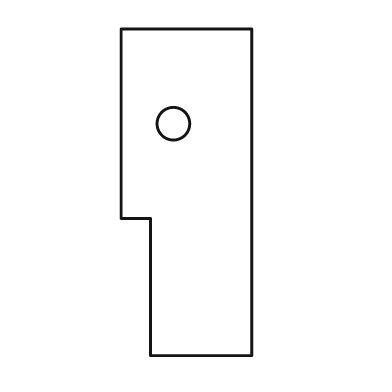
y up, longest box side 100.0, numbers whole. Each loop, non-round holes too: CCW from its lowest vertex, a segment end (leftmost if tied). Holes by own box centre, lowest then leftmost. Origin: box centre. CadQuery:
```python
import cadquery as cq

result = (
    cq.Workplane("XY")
    .moveTo(-11.0, -50.0)
    .lineTo(20.0, -50.0)
    .lineTo(20.0, 50.0)
    .lineTo(-20.0, 50.0)
    .lineTo(-20.0, -8.0)
    .lineTo(-11.0, -8.0)
    .close()
    .moveTo(-4.0, 21.0)
    .circle(5.0)
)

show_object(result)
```